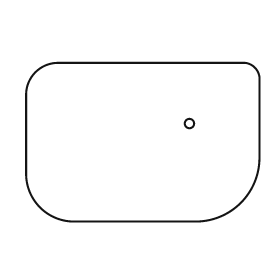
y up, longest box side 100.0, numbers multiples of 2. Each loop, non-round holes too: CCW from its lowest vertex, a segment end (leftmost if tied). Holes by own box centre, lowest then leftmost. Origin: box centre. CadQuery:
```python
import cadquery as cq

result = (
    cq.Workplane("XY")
    .moveTo(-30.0, -34.0)
    .lineTo(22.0, -34.0)
    .threePointArc((42.0, -26.0), (50.0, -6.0))
    .lineTo(50.0, 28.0)
    .threePointArc((48.0, 32.0), (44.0, 34.0))
    .lineTo(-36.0, 34.0)
    .threePointArc((-46.0, 30.0), (-50.0, 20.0))
    .lineTo(-50.0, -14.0)
    .threePointArc((-44.0, -28.0), (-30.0, -34.0))
    .close()
    .moveTo(20.0, 8.0)
    .circle(2.0)
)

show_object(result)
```